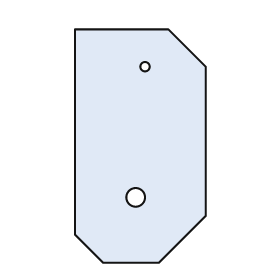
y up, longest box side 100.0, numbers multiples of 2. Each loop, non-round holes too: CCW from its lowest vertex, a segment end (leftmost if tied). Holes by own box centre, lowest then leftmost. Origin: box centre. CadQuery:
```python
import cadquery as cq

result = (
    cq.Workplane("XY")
    .moveTo(-16.0, -50.0)
    .lineTo(8.0, -50.0)
    .lineTo(28.0, -30.0)
    .lineTo(28.0, 34.0)
    .lineTo(12.0, 50.0)
    .lineTo(-28.0, 50.0)
    .lineTo(-28.0, -38.0)
    .close()
    .moveTo(-2.0, -22.0)
    .circle(4.0)
    .moveTo(2.0, 34.0)
    .circle(2.0)
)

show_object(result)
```